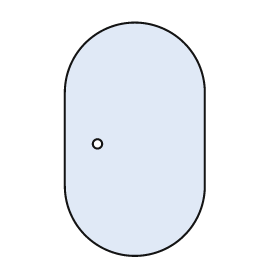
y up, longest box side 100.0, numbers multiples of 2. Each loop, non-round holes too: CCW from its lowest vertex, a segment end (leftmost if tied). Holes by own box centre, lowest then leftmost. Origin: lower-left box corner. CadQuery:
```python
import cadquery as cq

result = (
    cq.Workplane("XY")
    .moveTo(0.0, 30.0)
    .threePointArc((30.0, 0.0), (60.0, 30.0))
    .lineTo(60.0, 70.0)
    .threePointArc((30.0, 100.0), (0.0, 70.0))
    .close()
    .moveTo(14.0, 48.0)
    .circle(2.0)
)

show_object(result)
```